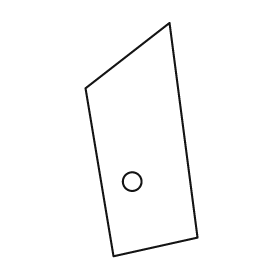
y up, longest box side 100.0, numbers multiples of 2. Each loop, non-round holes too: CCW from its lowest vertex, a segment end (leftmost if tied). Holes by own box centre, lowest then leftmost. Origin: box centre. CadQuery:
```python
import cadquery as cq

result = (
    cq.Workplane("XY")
    .moveTo(-12.0, -50.0)
    .lineTo(24.0, -42.0)
    .lineTo(12.0, 50.0)
    .lineTo(-24.0, 22.0)
    .close()
    .moveTo(-4.0, -18.0)
    .circle(4.0)
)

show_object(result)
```